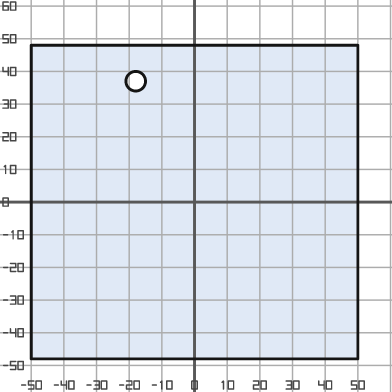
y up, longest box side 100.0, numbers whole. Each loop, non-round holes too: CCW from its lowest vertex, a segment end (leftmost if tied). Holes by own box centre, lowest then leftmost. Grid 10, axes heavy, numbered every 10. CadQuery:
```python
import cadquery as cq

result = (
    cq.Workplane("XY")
    .moveTo(-50.0, -48.0)
    .lineTo(50.0, -48.0)
    .lineTo(50.0, 48.0)
    .lineTo(-50.0, 48.0)
    .close()
    .moveTo(-18.0, 37.0)
    .circle(3.0)
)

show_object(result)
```